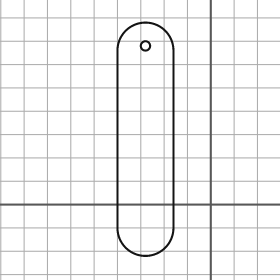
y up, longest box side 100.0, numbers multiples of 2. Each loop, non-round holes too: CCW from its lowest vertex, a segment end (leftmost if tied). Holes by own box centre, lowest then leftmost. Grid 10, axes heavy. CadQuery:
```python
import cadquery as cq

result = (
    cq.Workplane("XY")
    .moveTo(-40.0, -10.0)
    .threePointArc((-28.0, -22.0), (-16.0, -10.0))
    .lineTo(-16.0, 66.0)
    .threePointArc((-28.0, 78.0), (-40.0, 66.0))
    .close()
    .moveTo(-28.0, 68.0)
    .circle(2.0)
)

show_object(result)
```